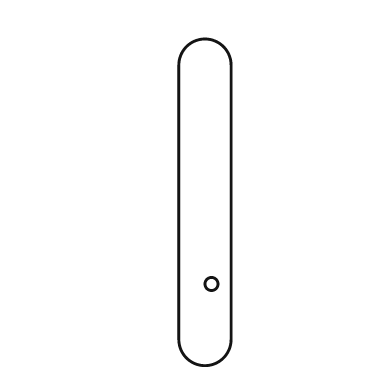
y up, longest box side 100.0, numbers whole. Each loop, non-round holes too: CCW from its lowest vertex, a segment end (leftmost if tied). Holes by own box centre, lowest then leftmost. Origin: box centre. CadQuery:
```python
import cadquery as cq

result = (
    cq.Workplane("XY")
    .moveTo(-8.0, -42.0)
    .threePointArc((0.0, -50.0), (8.0, -42.0))
    .lineTo(8.0, 42.0)
    .threePointArc((0.0, 50.0), (-8.0, 42.0))
    .close()
    .moveTo(2.0, -25.0)
    .circle(2.0)
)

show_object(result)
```